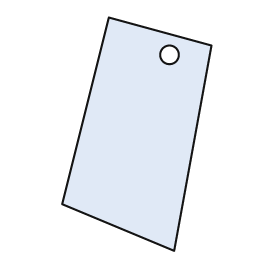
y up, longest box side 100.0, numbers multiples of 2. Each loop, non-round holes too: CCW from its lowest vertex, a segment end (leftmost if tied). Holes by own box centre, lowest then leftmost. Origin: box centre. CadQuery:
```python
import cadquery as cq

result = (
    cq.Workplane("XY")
    .moveTo(16.0, -50.0)
    .lineTo(32.0, 38.0)
    .lineTo(-12.0, 50.0)
    .lineTo(-32.0, -30.0)
    .close()
    .moveTo(14.0, 34.0)
    .circle(4.0)
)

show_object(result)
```